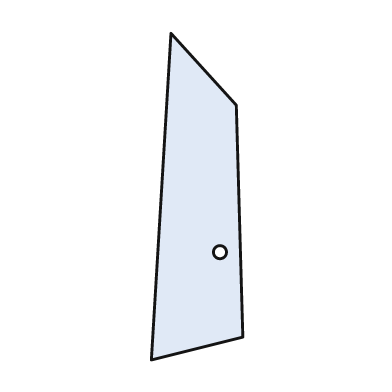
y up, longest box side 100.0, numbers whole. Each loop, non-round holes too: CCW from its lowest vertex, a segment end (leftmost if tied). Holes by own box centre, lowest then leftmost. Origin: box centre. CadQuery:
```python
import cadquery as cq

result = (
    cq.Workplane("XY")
    .moveTo(-14.0, -50.0)
    .lineTo(14.0, -43.0)
    .lineTo(12.0, 28.0)
    .lineTo(-8.0, 50.0)
    .close()
    .moveTo(7.0, -17.0)
    .circle(2.0)
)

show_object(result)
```